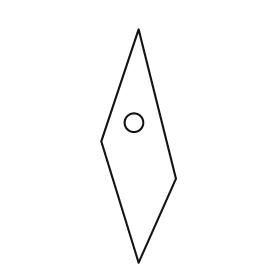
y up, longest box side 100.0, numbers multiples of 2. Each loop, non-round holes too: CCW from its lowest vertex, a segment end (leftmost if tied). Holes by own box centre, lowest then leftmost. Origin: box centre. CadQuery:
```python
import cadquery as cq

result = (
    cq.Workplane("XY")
    .moveTo(0.0, -50.0)
    .lineTo(16.0, -14.0)
    .lineTo(0.0, 50.0)
    .lineTo(-16.0, 2.0)
    .close()
    .moveTo(-2.0, 10.0)
    .circle(4.0)
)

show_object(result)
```